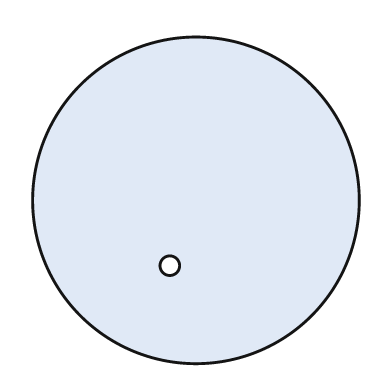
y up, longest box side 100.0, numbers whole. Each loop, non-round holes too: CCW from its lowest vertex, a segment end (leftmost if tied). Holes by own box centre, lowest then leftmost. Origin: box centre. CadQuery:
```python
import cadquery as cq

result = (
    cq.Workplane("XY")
    .moveTo(0.0, 0.0)
    .circle(50.0)
    .moveTo(-8.0, -20.0)
    .circle(3.0)
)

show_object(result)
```